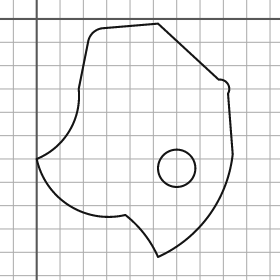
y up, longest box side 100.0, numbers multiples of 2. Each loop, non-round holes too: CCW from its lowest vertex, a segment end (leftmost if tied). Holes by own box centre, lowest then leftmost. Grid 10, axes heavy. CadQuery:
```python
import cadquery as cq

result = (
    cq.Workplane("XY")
    .moveTo(52.0, -102.0)
    .threePointArc((74.0, -84.0), (84.0, -58.0))
    .lineTo(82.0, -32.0)
    .threePointArc((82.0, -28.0), (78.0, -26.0))
    .lineTo(52.0, -2.0)
    .lineTo(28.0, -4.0)
    .threePointArc((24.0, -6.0), (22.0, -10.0))
    .lineTo(18.0, -30.0)
    .threePointArc((14.0, -48.0), (0.0, -60.0))
    .threePointArc((14.0, -80.0), (38.0, -84.0))
    .threePointArc((46.0, -92.0), (52.0, -102.0))
    .close()
    .moveTo(60.0, -64.0)
    .circle(8.0)
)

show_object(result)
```